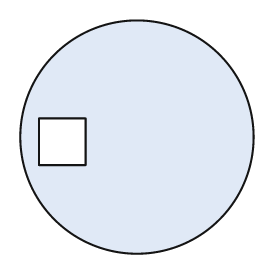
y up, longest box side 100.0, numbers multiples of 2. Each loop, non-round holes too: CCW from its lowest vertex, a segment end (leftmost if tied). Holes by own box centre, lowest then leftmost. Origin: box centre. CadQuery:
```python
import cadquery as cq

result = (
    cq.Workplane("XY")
    .moveTo(0.0, 0.0)
    .circle(50.0)
    .moveTo(-42.0, -12.0)
    .lineTo(-22.0, -12.0)
    .lineTo(-22.0, 8.0)
    .lineTo(-42.0, 8.0)
    .close()
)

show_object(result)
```